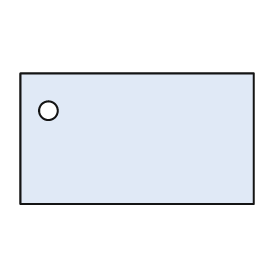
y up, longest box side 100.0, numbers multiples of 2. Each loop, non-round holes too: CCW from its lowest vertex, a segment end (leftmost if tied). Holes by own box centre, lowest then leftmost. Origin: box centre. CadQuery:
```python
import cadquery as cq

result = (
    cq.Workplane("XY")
    .moveTo(-50.0, -28.0)
    .lineTo(50.0, -28.0)
    .lineTo(50.0, 28.0)
    .lineTo(-50.0, 28.0)
    .close()
    .moveTo(-38.0, 12.0)
    .circle(4.0)
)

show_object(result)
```